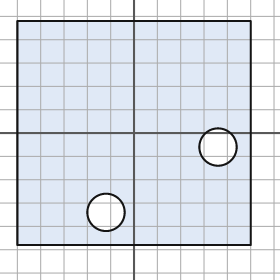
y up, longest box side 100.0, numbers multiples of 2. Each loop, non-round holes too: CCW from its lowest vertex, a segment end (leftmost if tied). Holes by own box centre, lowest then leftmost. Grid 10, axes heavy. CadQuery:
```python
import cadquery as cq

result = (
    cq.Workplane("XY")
    .moveTo(-50.0, -48.0)
    .lineTo(50.0, -48.0)
    .lineTo(50.0, 48.0)
    .lineTo(-50.0, 48.0)
    .close()
    .moveTo(-12.0, -34.0)
    .circle(8.0)
    .moveTo(36.0, -6.0)
    .circle(8.0)
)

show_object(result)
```